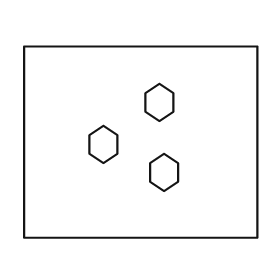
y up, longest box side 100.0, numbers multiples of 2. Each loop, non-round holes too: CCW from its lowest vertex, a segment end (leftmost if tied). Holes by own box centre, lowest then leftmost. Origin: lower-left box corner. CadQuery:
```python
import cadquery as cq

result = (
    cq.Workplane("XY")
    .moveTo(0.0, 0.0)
    .lineTo(100.0, 0.0)
    .lineTo(100.0, 82.0)
    .lineTo(0.0, 82.0)
    .close()
    .moveTo(60.0, 20.0)
    .lineTo(66.0, 24.0)
    .lineTo(66.0, 32.0)
    .lineTo(60.0, 36.0)
    .lineTo(54.0, 32.0)
    .lineTo(54.0, 24.0)
    .close()
    .moveTo(34.0, 32.0)
    .lineTo(40.0, 36.0)
    .lineTo(40.0, 44.0)
    .lineTo(34.0, 48.0)
    .lineTo(28.0, 44.0)
    .lineTo(28.0, 36.0)
    .close()
    .moveTo(58.0, 50.0)
    .lineTo(64.0, 54.0)
    .lineTo(64.0, 62.0)
    .lineTo(58.0, 66.0)
    .lineTo(52.0, 62.0)
    .lineTo(52.0, 54.0)
    .close()
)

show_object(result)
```